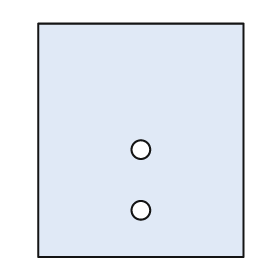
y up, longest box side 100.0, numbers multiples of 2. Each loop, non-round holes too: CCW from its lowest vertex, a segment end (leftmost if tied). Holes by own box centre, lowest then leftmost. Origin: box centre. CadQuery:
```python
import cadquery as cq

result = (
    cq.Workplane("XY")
    .moveTo(-44.0, -50.0)
    .lineTo(44.0, -50.0)
    .lineTo(44.0, 50.0)
    .lineTo(-44.0, 50.0)
    .close()
    .moveTo(0.0, -30.0)
    .circle(4.0)
    .moveTo(0.0, -4.0)
    .circle(4.0)
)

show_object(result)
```